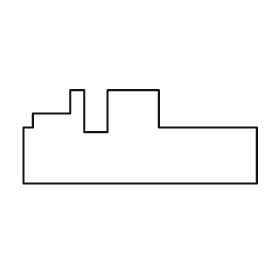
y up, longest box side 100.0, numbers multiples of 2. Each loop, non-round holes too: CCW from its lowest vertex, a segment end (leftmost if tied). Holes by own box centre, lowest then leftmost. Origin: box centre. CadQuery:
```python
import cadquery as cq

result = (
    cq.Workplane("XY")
    .moveTo(-50.0, -20.0)
    .lineTo(50.0, -20.0)
    .lineTo(50.0, 4.0)
    .lineTo(8.0, 4.0)
    .lineTo(8.0, 20.0)
    .lineTo(-14.0, 20.0)
    .lineTo(-14.0, 2.0)
    .lineTo(-24.0, 2.0)
    .lineTo(-24.0, 20.0)
    .lineTo(-30.0, 20.0)
    .lineTo(-30.0, 10.0)
    .lineTo(-46.0, 10.0)
    .lineTo(-46.0, 4.0)
    .lineTo(-50.0, 4.0)
    .close()
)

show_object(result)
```